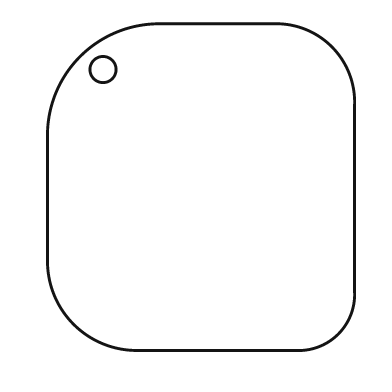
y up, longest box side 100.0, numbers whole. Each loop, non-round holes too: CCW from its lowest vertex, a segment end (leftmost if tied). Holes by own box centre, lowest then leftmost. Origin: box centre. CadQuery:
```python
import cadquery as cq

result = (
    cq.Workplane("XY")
    .moveTo(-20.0, -50.0)
    .lineTo(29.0, -50.0)
    .threePointArc((42.0, -45.0), (47.0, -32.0))
    .lineTo(47.0, 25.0)
    .threePointArc((40.0, 43.0), (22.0, 50.0))
    .lineTo(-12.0, 50.0)
    .threePointArc((-37.0, 40.0), (-47.0, 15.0))
    .lineTo(-47.0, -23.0)
    .threePointArc((-39.0, -42.0), (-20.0, -50.0))
    .close()
    .moveTo(-30.0, 36.0)
    .circle(4.0)
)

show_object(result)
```